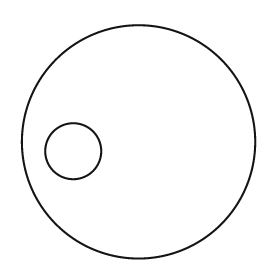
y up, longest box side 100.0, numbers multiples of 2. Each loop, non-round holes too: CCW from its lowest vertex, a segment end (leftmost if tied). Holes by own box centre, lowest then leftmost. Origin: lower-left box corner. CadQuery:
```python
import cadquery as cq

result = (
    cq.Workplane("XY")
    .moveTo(50.0, 50.0)
    .circle(50.0)
    .moveTo(22.0, 46.0)
    .circle(12.0)
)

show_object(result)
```